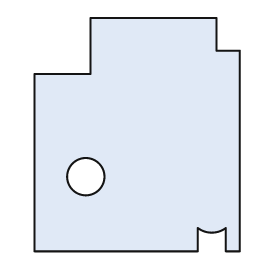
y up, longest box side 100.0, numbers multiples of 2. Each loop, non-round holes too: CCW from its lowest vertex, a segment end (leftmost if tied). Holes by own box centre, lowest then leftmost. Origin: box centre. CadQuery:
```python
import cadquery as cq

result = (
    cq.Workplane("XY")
    .moveTo(-44.0, -50.0)
    .lineTo(26.0, -50.0)
    .lineTo(26.0, -40.0)
    .threePointArc((32.0, -42.0), (38.0, -40.0))
    .lineTo(38.0, -50.0)
    .lineTo(44.0, -50.0)
    .lineTo(44.0, 36.0)
    .lineTo(34.0, 36.0)
    .lineTo(34.0, 50.0)
    .lineTo(-20.0, 50.0)
    .lineTo(-20.0, 26.0)
    .lineTo(-44.0, 26.0)
    .close()
    .moveTo(-22.0, -18.0)
    .circle(8.0)
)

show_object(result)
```